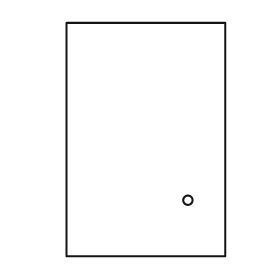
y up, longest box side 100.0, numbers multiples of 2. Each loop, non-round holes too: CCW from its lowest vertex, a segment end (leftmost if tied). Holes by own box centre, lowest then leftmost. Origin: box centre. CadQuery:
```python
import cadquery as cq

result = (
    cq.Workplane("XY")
    .moveTo(-34.0, -50.0)
    .lineTo(34.0, -50.0)
    .lineTo(34.0, 50.0)
    .lineTo(-34.0, 50.0)
    .close()
    .moveTo(18.0, -26.0)
    .circle(2.0)
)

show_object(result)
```